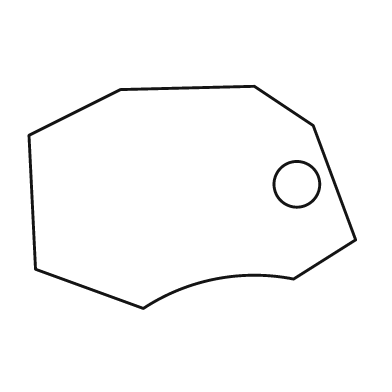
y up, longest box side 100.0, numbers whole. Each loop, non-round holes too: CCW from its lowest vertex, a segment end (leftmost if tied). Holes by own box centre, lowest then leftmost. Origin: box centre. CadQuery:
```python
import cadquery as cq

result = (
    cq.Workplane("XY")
    .moveTo(-15.0, -34.0)
    .threePointArc((7.0, -25.0), (31.0, -25.0))
    .lineTo(50.0, -13.0)
    .lineTo(37.0, 22.0)
    .lineTo(19.0, 34.0)
    .lineTo(-22.0, 33.0)
    .lineTo(-50.0, 19.0)
    .lineTo(-48.0, -22.0)
    .close()
    .moveTo(32.0, 4.0)
    .circle(7.0)
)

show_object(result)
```